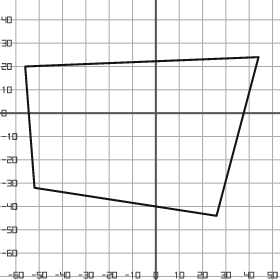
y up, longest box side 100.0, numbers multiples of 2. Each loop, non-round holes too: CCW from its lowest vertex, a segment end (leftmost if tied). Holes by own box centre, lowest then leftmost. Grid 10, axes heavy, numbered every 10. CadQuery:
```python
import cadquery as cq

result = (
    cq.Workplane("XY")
    .moveTo(26.0, -44.0)
    .lineTo(44.0, 24.0)
    .lineTo(-56.0, 20.0)
    .lineTo(-52.0, -32.0)
    .close()
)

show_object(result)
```